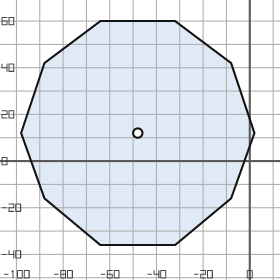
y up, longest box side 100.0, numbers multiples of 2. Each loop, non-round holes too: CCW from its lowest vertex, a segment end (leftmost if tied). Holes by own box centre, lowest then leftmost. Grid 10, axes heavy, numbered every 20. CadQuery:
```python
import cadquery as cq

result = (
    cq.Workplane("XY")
    .moveTo(-64.0, -36.0)
    .lineTo(-32.0, -36.0)
    .lineTo(-8.0, -16.0)
    .lineTo(2.0, 12.0)
    .lineTo(-8.0, 42.0)
    .lineTo(-32.0, 60.0)
    .lineTo(-64.0, 60.0)
    .lineTo(-88.0, 42.0)
    .lineTo(-98.0, 12.0)
    .lineTo(-88.0, -16.0)
    .close()
    .moveTo(-48.0, 12.0)
    .circle(2.0)
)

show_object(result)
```